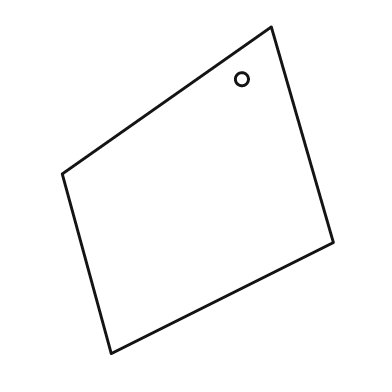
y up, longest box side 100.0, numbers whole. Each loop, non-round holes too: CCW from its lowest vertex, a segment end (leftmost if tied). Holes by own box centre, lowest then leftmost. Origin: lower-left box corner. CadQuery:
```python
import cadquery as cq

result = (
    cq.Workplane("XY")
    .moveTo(15.0, 0.0)
    .lineTo(83.0, 34.0)
    .lineTo(64.0, 100.0)
    .lineTo(0.0, 55.0)
    .close()
    .moveTo(55.0, 84.0)
    .circle(2.0)
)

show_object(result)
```